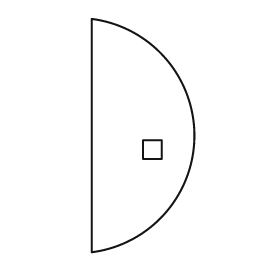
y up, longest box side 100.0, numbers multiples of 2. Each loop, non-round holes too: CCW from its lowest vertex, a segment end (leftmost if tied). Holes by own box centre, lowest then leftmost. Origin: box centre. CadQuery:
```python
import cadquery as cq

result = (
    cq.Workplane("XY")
    .moveTo(-22.0, -50.0)
    .threePointArc((22.0, 0.0), (-22.0, 50.0))
    .close()
    .moveTo(0.0, -10.0)
    .lineTo(8.0, -10.0)
    .lineTo(8.0, -2.0)
    .lineTo(0.0, -2.0)
    .close()
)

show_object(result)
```